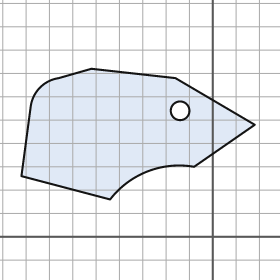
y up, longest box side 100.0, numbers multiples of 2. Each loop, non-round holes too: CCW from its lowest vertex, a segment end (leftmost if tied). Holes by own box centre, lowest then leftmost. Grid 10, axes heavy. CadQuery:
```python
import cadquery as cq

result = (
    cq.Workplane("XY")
    .moveTo(-44.0, 16.0)
    .threePointArc((-28.0, 28.0), (-8.0, 30.0))
    .lineTo(18.0, 48.0)
    .lineTo(-16.0, 68.0)
    .lineTo(-52.0, 72.0)
    .lineTo(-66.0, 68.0)
    .threePointArc((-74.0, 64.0), (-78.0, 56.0))
    .lineTo(-82.0, 26.0)
    .close()
    .moveTo(-14.0, 54.0)
    .circle(4.0)
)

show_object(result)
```